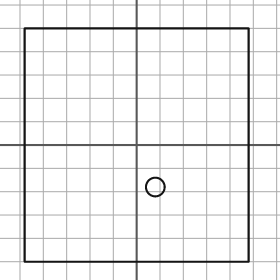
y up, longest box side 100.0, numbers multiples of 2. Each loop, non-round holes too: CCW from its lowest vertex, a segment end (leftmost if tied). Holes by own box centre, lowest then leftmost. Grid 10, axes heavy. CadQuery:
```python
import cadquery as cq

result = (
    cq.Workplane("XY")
    .moveTo(-48.0, -50.0)
    .lineTo(48.0, -50.0)
    .lineTo(48.0, 50.0)
    .lineTo(-48.0, 50.0)
    .close()
    .moveTo(8.0, -18.0)
    .circle(4.0)
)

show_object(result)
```